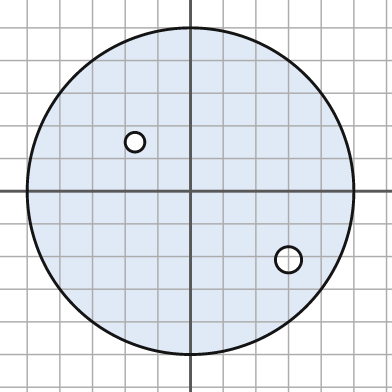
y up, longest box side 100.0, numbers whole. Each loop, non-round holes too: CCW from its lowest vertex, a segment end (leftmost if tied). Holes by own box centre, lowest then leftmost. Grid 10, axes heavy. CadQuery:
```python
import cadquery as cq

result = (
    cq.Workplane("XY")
    .moveTo(0.0, 0.0)
    .circle(50.0)
    .moveTo(30.0, -21.0)
    .circle(4.0)
    .moveTo(-17.0, 15.0)
    .circle(3.0)
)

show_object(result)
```